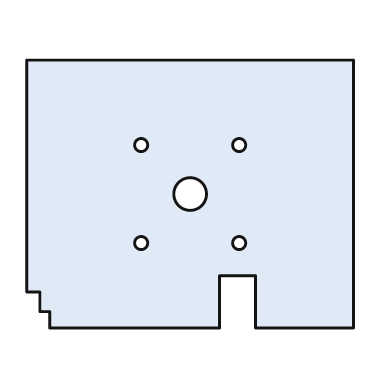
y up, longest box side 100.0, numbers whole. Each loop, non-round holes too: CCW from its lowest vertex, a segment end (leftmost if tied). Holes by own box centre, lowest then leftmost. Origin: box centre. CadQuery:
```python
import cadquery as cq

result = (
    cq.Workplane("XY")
    .moveTo(-43.0, -41.0)
    .lineTo(9.0, -41.0)
    .lineTo(9.0, -25.0)
    .lineTo(20.0, -25.0)
    .lineTo(20.0, -41.0)
    .lineTo(50.0, -41.0)
    .lineTo(50.0, 41.0)
    .lineTo(-50.0, 41.0)
    .lineTo(-50.0, -30.0)
    .lineTo(-46.0, -30.0)
    .lineTo(-46.0, -36.0)
    .lineTo(-43.0, -36.0)
    .close()
    .moveTo(-15.0, -15.0)
    .circle(2.0)
    .moveTo(15.0, -15.0)
    .circle(2.0)
    .moveTo(0.0, 0.0)
    .circle(5.0)
    .moveTo(-15.0, 15.0)
    .circle(2.0)
    .moveTo(15.0, 15.0)
    .circle(2.0)
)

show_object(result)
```